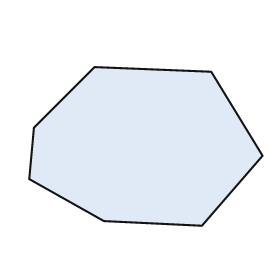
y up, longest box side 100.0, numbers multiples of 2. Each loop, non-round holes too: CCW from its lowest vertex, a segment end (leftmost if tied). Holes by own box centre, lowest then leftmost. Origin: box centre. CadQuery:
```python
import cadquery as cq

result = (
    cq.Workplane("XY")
    .moveTo(24.0, -34.0)
    .lineTo(50.0, -4.0)
    .lineTo(28.0, 32.0)
    .lineTo(-22.0, 34.0)
    .lineTo(-48.0, 8.0)
    .lineTo(-50.0, -14.0)
    .lineTo(-18.0, -32.0)
    .close()
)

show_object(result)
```